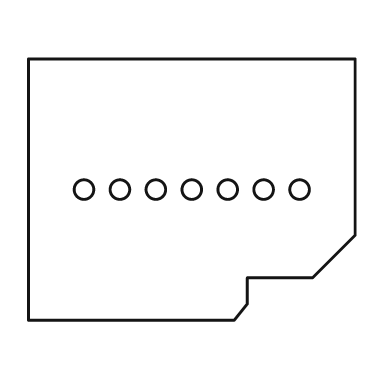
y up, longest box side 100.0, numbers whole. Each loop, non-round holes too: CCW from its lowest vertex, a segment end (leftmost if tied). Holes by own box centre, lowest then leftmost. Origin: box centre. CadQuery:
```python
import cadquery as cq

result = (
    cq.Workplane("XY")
    .moveTo(-50.0, -40.0)
    .lineTo(13.0, -40.0)
    .lineTo(17.0, -35.0)
    .lineTo(17.0, -27.0)
    .lineTo(37.0, -27.0)
    .lineTo(50.0, -14.0)
    .lineTo(50.0, 40.0)
    .lineTo(-50.0, 40.0)
    .close()
    .moveTo(-33.0, 0.0)
    .circle(3.0)
    .moveTo(-22.0, 0.0)
    .circle(3.0)
    .moveTo(-11.0, 0.0)
    .circle(3.0)
    .moveTo(0.0, 0.0)
    .circle(3.0)
    .moveTo(11.0, 0.0)
    .circle(3.0)
    .moveTo(22.0, 0.0)
    .circle(3.0)
    .moveTo(33.0, 0.0)
    .circle(3.0)
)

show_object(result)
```